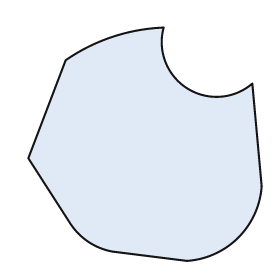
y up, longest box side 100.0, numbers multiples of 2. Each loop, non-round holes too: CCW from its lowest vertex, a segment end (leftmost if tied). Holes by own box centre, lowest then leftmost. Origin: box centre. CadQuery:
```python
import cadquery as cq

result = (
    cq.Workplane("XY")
    .moveTo(18.0, -50.0)
    .threePointArc((40.0, -40.0), (50.0, -18.0))
    .lineTo(46.0, 26.0)
    .threePointArc((18.0, 24.0), (8.0, 50.0))
    .threePointArc((-14.0, 46.0), (-34.0, 36.0))
    .lineTo(-50.0, -6.0)
    .lineTo(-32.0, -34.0)
    .threePointArc((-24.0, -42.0), (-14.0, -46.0))
    .close()
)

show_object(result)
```